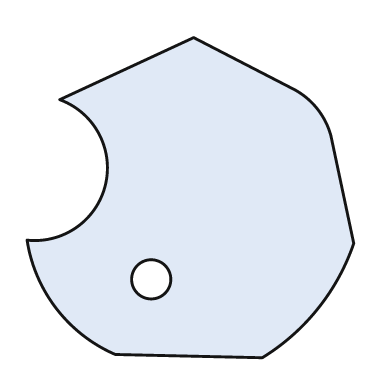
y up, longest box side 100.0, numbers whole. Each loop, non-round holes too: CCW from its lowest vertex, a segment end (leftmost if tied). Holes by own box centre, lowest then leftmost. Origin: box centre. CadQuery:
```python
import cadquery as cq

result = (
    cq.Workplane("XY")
    .moveTo(22.0, -49.0)
    .threePointArc((39.0, -34.0), (50.0, -14.0))
    .lineTo(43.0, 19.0)
    .threePointArc((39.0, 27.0), (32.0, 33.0))
    .lineTo(1.0, 49.0)
    .lineTo(-40.0, 30.0)
    .threePointArc((-26.0, 4.0), (-50.0, -13.0))
    .threePointArc((-41.0, -34.0), (-23.0, -48.0))
    .close()
    .moveTo(-12.0, -25.0)
    .circle(6.0)
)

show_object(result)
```